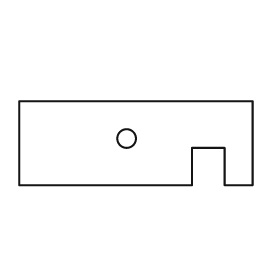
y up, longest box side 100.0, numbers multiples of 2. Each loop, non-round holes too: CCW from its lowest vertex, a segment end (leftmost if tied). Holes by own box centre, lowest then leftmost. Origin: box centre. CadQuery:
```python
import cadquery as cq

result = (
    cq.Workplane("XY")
    .moveTo(-50.0, -18.0)
    .lineTo(24.0, -18.0)
    .lineTo(24.0, -2.0)
    .lineTo(38.0, -2.0)
    .lineTo(38.0, -18.0)
    .lineTo(50.0, -18.0)
    .lineTo(50.0, 18.0)
    .lineTo(-50.0, 18.0)
    .close()
    .moveTo(-4.0, 2.0)
    .circle(4.0)
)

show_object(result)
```